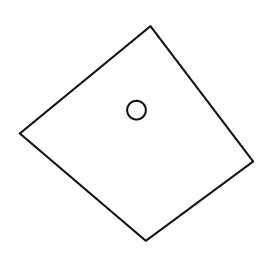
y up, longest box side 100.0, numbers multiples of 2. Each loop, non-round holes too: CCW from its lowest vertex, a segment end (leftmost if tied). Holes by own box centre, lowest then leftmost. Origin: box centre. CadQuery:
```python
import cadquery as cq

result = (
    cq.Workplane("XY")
    .moveTo(4.0, -46.0)
    .lineTo(50.0, -12.0)
    .lineTo(6.0, 46.0)
    .lineTo(-50.0, 0.0)
    .close()
    .moveTo(0.0, 10.0)
    .circle(4.0)
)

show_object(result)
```